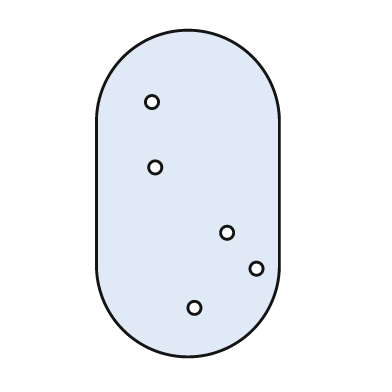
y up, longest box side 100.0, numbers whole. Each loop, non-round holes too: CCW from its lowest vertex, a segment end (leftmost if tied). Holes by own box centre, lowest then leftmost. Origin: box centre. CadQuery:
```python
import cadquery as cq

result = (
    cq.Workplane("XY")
    .moveTo(-28.0, -22.0)
    .threePointArc((0.0, -50.0), (28.0, -22.0))
    .lineTo(28.0, 22.0)
    .threePointArc((0.0, 50.0), (-28.0, 22.0))
    .close()
    .moveTo(2.0, -35.0)
    .circle(2.0)
    .moveTo(21.0, -23.0)
    .circle(2.0)
    .moveTo(12.0, -12.0)
    .circle(2.0)
    .moveTo(-10.0, 8.0)
    .circle(2.0)
    .moveTo(-11.0, 28.0)
    .circle(2.0)
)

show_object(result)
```